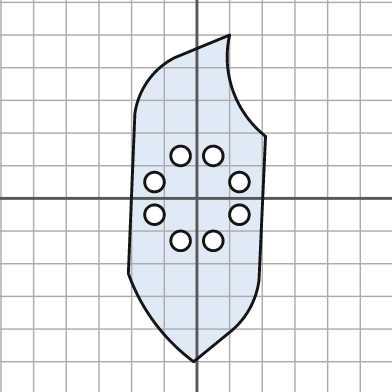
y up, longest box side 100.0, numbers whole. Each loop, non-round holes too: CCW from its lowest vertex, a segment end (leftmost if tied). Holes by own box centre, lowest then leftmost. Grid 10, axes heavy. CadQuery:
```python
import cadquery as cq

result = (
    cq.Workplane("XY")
    .moveTo(-1.0, -50.0)
    .lineTo(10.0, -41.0)
    .threePointArc((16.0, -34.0), (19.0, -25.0))
    .lineTo(21.0, 19.0)
    .threePointArc((11.0, 33.0), (10.0, 50.0))
    .lineTo(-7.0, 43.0)
    .threePointArc((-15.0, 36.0), (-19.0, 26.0))
    .lineTo(-21.0, -23.0)
    .threePointArc((-13.0, -38.0), (-1.0, -50.0))
    .close()
    .moveTo(-5.0, -13.0)
    .circle(3.0)
    .moveTo(5.0, -13.0)
    .circle(3.0)
    .moveTo(-13.0, -5.0)
    .circle(3.0)
    .moveTo(13.0, -5.0)
    .circle(3.0)
    .moveTo(-13.0, 5.0)
    .circle(3.0)
    .moveTo(13.0, 5.0)
    .circle(3.0)
    .moveTo(-5.0, 13.0)
    .circle(3.0)
    .moveTo(5.0, 13.0)
    .circle(3.0)
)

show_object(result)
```